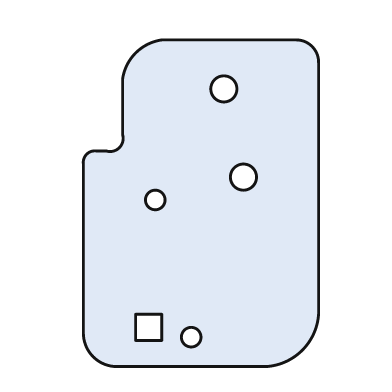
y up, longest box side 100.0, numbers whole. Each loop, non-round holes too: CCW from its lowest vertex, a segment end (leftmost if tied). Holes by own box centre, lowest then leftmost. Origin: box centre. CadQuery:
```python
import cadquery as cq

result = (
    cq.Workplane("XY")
    .moveTo(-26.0, -50.0)
    .lineTo(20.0, -50.0)
    .threePointArc((31.0, -45.0), (36.0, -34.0))
    .lineTo(36.0, 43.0)
    .threePointArc((34.0, 48.0), (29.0, 50.0))
    .lineTo(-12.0, 50.0)
    .threePointArc((-20.0, 46.0), (-24.0, 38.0))
    .lineTo(-24.0, 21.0)
    .threePointArc((-25.0, 17.0), (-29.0, 16.0))
    .lineTo(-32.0, 16.0)
    .threePointArc((-35.0, 15.0), (-36.0, 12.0))
    .lineTo(-36.0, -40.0)
    .threePointArc((-33.0, -47.0), (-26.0, -50.0))
    .close()
    .moveTo(-3.0, -41.0)
    .circle(3.0)
    .moveTo(-20.0, -42.0)
    .lineTo(-12.0, -42.0)
    .lineTo(-12.0, -34.0)
    .lineTo(-20.0, -34.0)
    .close()
    .moveTo(-14.0, 1.0)
    .circle(3.0)
    .moveTo(13.0, 8.0)
    .circle(4.0)
    .moveTo(7.0, 35.0)
    .circle(4.0)
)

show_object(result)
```